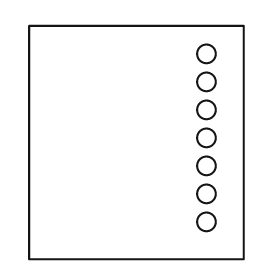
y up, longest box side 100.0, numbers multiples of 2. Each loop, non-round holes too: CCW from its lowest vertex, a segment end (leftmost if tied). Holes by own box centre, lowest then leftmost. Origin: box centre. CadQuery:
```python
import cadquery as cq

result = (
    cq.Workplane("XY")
    .moveTo(-46.0, -50.0)
    .lineTo(46.0, -50.0)
    .lineTo(46.0, 50.0)
    .lineTo(-46.0, 50.0)
    .close()
    .moveTo(30.0, -34.0)
    .circle(4.0)
    .moveTo(30.0, -22.0)
    .circle(4.0)
    .moveTo(30.0, -10.0)
    .circle(4.0)
    .moveTo(30.0, 2.0)
    .circle(4.0)
    .moveTo(30.0, 14.0)
    .circle(4.0)
    .moveTo(30.0, 26.0)
    .circle(4.0)
    .moveTo(30.0, 38.0)
    .circle(4.0)
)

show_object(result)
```